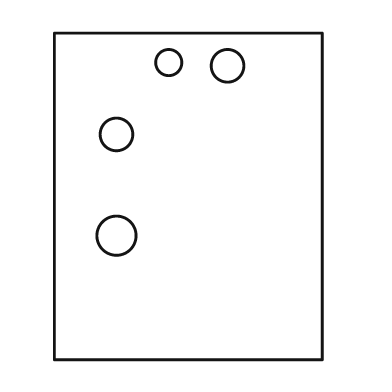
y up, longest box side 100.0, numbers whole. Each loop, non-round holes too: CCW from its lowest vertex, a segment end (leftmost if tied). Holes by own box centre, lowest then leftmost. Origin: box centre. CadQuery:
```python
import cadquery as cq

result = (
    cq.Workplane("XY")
    .moveTo(-41.0, -50.0)
    .lineTo(41.0, -50.0)
    .lineTo(41.0, 50.0)
    .lineTo(-41.0, 50.0)
    .close()
    .moveTo(-22.0, -12.0)
    .circle(6.0)
    .moveTo(-22.0, 19.0)
    .circle(5.0)
    .moveTo(12.0, 40.0)
    .circle(5.0)
    .moveTo(-6.0, 41.0)
    .circle(4.0)
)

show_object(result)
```